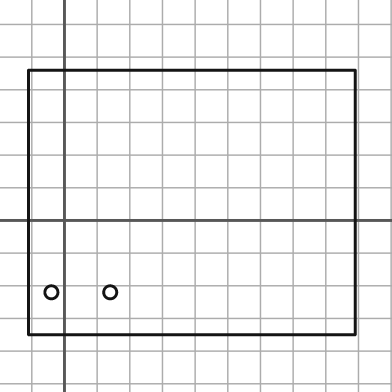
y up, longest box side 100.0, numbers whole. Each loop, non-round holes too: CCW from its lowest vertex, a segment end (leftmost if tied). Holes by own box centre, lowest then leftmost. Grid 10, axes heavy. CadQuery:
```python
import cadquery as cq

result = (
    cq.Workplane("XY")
    .moveTo(-11.0, -35.0)
    .lineTo(89.0, -35.0)
    .lineTo(89.0, 46.0)
    .lineTo(-11.0, 46.0)
    .close()
    .moveTo(-4.0, -22.0)
    .circle(2.0)
    .moveTo(14.0, -22.0)
    .circle(2.0)
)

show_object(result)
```